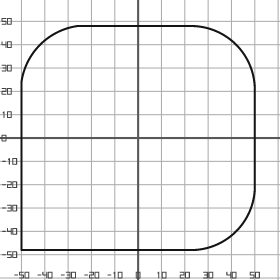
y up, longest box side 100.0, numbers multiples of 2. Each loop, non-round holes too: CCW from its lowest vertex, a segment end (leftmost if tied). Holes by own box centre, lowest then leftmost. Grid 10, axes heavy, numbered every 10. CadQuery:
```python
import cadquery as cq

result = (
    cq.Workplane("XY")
    .moveTo(-50.0, -48.0)
    .lineTo(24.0, -48.0)
    .threePointArc((42.0, -40.0), (50.0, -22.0))
    .lineTo(50.0, 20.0)
    .threePointArc((42.0, 40.0), (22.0, 48.0))
    .lineTo(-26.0, 48.0)
    .threePointArc((-42.0, 40.0), (-50.0, 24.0))
    .close()
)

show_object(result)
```